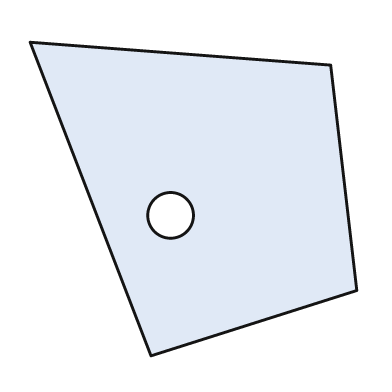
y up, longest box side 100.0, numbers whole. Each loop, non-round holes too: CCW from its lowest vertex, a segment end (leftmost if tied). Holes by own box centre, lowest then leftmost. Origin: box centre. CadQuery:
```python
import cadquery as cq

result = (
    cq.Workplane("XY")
    .moveTo(-13.0, -48.0)
    .lineTo(50.0, -28.0)
    .lineTo(42.0, 41.0)
    .lineTo(-50.0, 48.0)
    .close()
    .moveTo(-7.0, -5.0)
    .circle(7.0)
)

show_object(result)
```